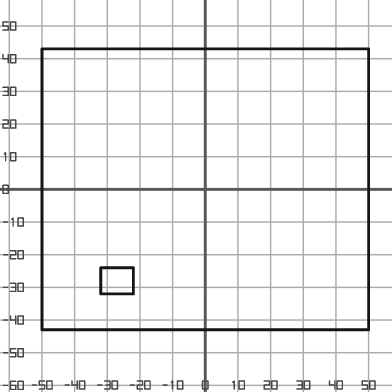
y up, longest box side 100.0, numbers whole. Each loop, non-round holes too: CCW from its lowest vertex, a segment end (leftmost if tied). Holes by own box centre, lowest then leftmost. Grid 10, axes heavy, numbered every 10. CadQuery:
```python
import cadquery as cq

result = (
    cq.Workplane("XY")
    .moveTo(-50.0, -43.0)
    .lineTo(50.0, -43.0)
    .lineTo(50.0, 43.0)
    .lineTo(-50.0, 43.0)
    .close()
    .moveTo(-32.0, -32.0)
    .lineTo(-22.0, -32.0)
    .lineTo(-22.0, -24.0)
    .lineTo(-32.0, -24.0)
    .close()
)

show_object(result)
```